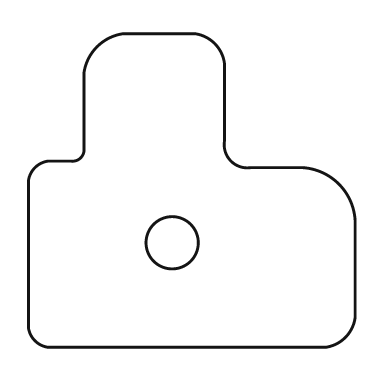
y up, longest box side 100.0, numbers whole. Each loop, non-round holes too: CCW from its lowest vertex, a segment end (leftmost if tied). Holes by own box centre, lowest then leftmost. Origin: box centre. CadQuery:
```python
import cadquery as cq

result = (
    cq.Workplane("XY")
    .moveTo(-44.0, -48.0)
    .lineTo(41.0, -48.0)
    .threePointArc((47.0, -45.0), (50.0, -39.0))
    .lineTo(50.0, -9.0)
    .threePointArc((45.0, 2.0), (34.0, 7.0))
    .lineTo(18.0, 7.0)
    .threePointArc((12.0, 9.0), (10.0, 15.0))
    .lineTo(10.0, 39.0)
    .threePointArc((7.0, 45.0), (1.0, 48.0))
    .lineTo(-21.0, 48.0)
    .threePointArc((-29.0, 44.0), (-33.0, 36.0))
    .lineTo(-33.0, 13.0)
    .threePointArc((-34.0, 10.0), (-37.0, 9.0))
    .lineTo(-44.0, 9.0)
    .threePointArc((-48.0, 7.0), (-50.0, 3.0))
    .lineTo(-50.0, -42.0)
    .threePointArc((-48.0, -46.0), (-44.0, -48.0))
    .close()
    .moveTo(-6.0, -16.0)
    .circle(8.0)
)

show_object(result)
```